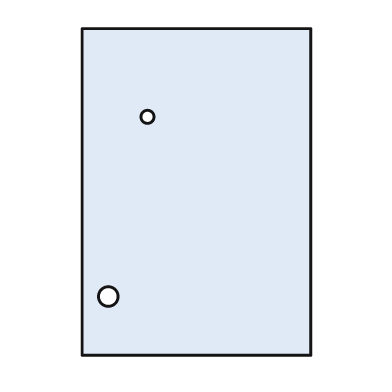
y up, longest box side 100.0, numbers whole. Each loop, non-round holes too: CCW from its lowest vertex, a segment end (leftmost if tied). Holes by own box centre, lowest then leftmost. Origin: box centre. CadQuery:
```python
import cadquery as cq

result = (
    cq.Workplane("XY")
    .moveTo(-35.0, -50.0)
    .lineTo(35.0, -50.0)
    .lineTo(35.0, 50.0)
    .lineTo(-35.0, 50.0)
    .close()
    .moveTo(-27.0, -32.0)
    .circle(3.0)
    .moveTo(-15.0, 23.0)
    .circle(2.0)
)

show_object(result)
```